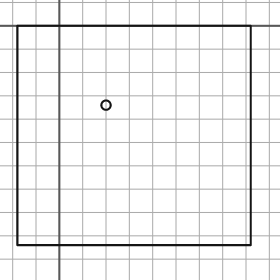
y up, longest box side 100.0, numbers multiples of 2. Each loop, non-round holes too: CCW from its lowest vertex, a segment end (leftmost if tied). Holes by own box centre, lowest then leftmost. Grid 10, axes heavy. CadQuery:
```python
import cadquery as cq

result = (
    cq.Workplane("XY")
    .moveTo(-18.0, -94.0)
    .lineTo(82.0, -94.0)
    .lineTo(82.0, 0.0)
    .lineTo(-18.0, 0.0)
    .close()
    .moveTo(20.0, -34.0)
    .circle(2.0)
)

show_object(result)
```